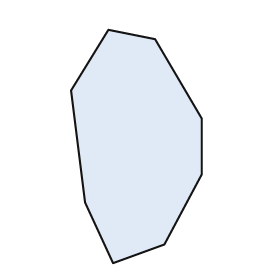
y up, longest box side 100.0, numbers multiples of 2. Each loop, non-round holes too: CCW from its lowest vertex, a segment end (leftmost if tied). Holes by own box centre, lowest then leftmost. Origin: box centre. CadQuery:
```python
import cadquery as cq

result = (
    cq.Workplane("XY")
    .moveTo(-10.0, -50.0)
    .lineTo(12.0, -42.0)
    .lineTo(28.0, -12.0)
    .lineTo(28.0, 12.0)
    .lineTo(8.0, 46.0)
    .lineTo(-12.0, 50.0)
    .lineTo(-28.0, 24.0)
    .lineTo(-22.0, -24.0)
    .close()
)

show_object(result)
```